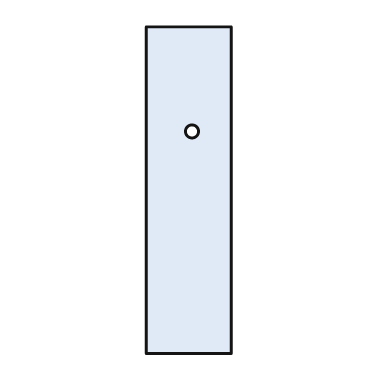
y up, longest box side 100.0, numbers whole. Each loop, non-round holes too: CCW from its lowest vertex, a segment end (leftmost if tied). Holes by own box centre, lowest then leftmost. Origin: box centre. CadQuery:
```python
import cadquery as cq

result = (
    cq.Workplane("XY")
    .moveTo(-13.0, -50.0)
    .lineTo(13.0, -50.0)
    .lineTo(13.0, 50.0)
    .lineTo(-13.0, 50.0)
    .close()
    .moveTo(1.0, 18.0)
    .circle(2.0)
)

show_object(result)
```